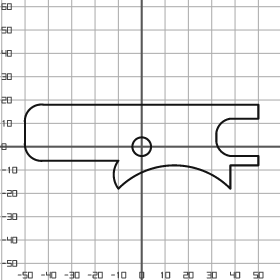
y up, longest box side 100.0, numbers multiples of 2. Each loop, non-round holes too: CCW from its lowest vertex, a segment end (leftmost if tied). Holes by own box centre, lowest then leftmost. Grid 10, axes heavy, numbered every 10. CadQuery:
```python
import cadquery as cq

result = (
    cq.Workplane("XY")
    .moveTo(-10.0, -18.0)
    .threePointArc((14.0, -8.0), (38.0, -18.0))
    .lineTo(38.0, -8.0)
    .lineTo(50.0, -8.0)
    .lineTo(50.0, -4.0)
    .lineTo(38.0, -4.0)
    .threePointArc((34.0, -2.0), (32.0, 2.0))
    .lineTo(32.0, 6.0)
    .threePointArc((34.0, 10.0), (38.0, 12.0))
    .lineTo(50.0, 12.0)
    .lineTo(50.0, 18.0)
    .lineTo(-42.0, 18.0)
    .threePointArc((-48.0, 16.0), (-50.0, 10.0))
    .lineTo(-50.0, 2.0)
    .threePointArc((-48.0, -4.0), (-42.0, -6.0))
    .lineTo(-10.0, -6.0)
    .threePointArc((-12.0, -12.0), (-10.0, -18.0))
    .close()
    .moveTo(0.0, 0.0)
    .circle(4.0)
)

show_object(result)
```